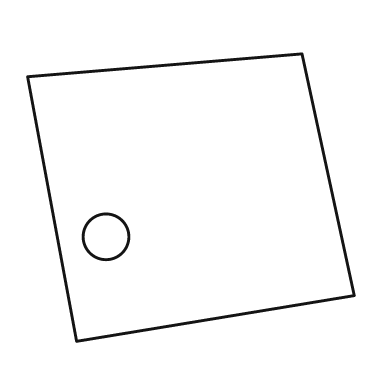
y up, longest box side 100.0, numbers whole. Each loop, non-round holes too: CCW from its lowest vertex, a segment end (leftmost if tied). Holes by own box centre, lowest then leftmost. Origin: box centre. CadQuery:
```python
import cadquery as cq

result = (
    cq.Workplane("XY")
    .moveTo(-35.0, -44.0)
    .lineTo(50.0, -30.0)
    .lineTo(34.0, 44.0)
    .lineTo(-50.0, 37.0)
    .close()
    .moveTo(-26.0, -12.0)
    .circle(7.0)
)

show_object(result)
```